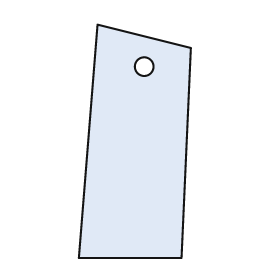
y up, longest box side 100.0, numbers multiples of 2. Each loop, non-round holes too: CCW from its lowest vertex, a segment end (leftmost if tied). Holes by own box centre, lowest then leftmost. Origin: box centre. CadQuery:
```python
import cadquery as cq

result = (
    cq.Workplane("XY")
    .moveTo(-24.0, -50.0)
    .lineTo(20.0, -50.0)
    .lineTo(24.0, 40.0)
    .lineTo(-16.0, 50.0)
    .close()
    .moveTo(4.0, 32.0)
    .circle(4.0)
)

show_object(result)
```